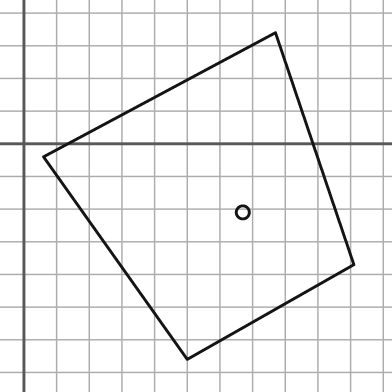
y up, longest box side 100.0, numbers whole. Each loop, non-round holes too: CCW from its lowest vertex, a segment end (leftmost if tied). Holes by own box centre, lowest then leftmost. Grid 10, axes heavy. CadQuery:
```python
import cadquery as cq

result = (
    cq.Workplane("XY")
    .moveTo(50.0, -66.0)
    .lineTo(101.0, -37.0)
    .lineTo(77.0, 34.0)
    .lineTo(6.0, -4.0)
    .close()
    .moveTo(67.0, -21.0)
    .circle(2.0)
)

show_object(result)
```